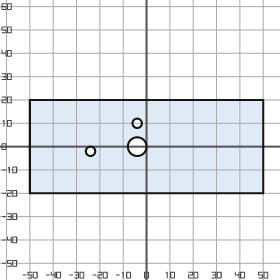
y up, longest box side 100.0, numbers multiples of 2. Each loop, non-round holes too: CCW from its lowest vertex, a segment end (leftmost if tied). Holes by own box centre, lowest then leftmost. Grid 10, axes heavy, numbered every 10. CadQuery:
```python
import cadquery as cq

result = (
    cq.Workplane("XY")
    .moveTo(-50.0, -20.0)
    .lineTo(50.0, -20.0)
    .lineTo(50.0, 20.0)
    .lineTo(-50.0, 20.0)
    .close()
    .moveTo(-24.0, -2.0)
    .circle(2.0)
    .moveTo(-4.0, 0.0)
    .circle(4.0)
    .moveTo(-4.0, 10.0)
    .circle(2.0)
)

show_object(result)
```